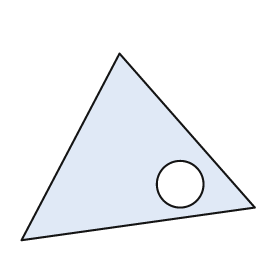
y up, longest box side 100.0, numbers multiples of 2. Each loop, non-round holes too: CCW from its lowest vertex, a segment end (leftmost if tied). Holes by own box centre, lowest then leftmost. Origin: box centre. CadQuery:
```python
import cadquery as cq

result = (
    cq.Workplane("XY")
    .moveTo(-50.0, -40.0)
    .lineTo(50.0, -26.0)
    .lineTo(-8.0, 40.0)
    .close()
    .moveTo(18.0, -16.0)
    .circle(10.0)
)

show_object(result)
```